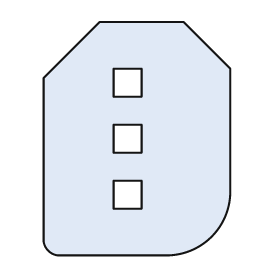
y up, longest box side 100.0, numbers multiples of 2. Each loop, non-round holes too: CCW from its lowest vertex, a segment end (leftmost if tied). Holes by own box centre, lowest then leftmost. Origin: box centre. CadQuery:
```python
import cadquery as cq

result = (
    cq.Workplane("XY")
    .moveTo(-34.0, -50.0)
    .lineTo(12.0, -50.0)
    .threePointArc((32.0, -42.0), (40.0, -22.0))
    .lineTo(40.0, 30.0)
    .lineTo(20.0, 50.0)
    .lineTo(-16.0, 50.0)
    .lineTo(-40.0, 26.0)
    .lineTo(-40.0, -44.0)
    .threePointArc((-38.0, -48.0), (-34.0, -50.0))
    .close()
    .moveTo(-10.0, -30.0)
    .lineTo(2.0, -30.0)
    .lineTo(2.0, -18.0)
    .lineTo(-10.0, -18.0)
    .close()
    .moveTo(-10.0, -6.0)
    .lineTo(2.0, -6.0)
    .lineTo(2.0, 6.0)
    .lineTo(-10.0, 6.0)
    .close()
    .moveTo(-10.0, 18.0)
    .lineTo(2.0, 18.0)
    .lineTo(2.0, 30.0)
    .lineTo(-10.0, 30.0)
    .close()
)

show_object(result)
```